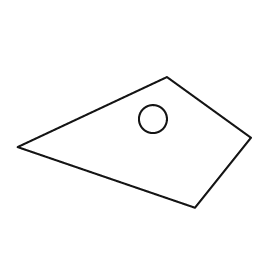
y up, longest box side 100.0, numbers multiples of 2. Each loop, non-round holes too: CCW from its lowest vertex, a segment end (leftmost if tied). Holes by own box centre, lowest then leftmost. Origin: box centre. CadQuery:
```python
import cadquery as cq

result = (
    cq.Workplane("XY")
    .moveTo(26.0, -28.0)
    .lineTo(50.0, 2.0)
    .lineTo(14.0, 28.0)
    .lineTo(-50.0, -2.0)
    .close()
    .moveTo(8.0, 10.0)
    .circle(6.0)
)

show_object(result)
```